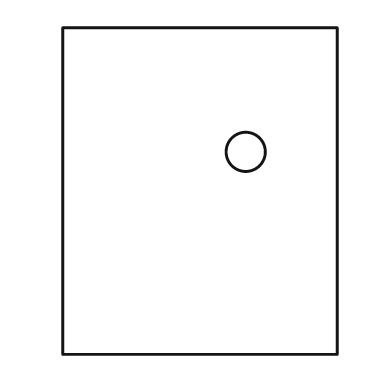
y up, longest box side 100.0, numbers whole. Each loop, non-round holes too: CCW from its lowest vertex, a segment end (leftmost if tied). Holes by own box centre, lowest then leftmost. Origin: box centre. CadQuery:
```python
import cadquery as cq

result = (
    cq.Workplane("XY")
    .moveTo(-42.0, -50.0)
    .lineTo(42.0, -50.0)
    .lineTo(42.0, 50.0)
    .lineTo(-42.0, 50.0)
    .close()
    .moveTo(14.0, 12.0)
    .circle(6.0)
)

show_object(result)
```